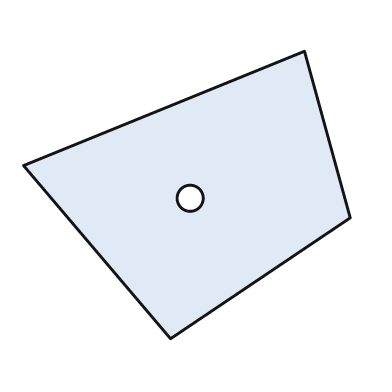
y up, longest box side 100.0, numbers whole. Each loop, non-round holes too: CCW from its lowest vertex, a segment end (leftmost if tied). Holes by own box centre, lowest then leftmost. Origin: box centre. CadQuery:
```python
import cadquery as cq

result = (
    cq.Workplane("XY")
    .moveTo(-5.0, -44.0)
    .lineTo(50.0, -7.0)
    .lineTo(36.0, 44.0)
    .lineTo(-50.0, 9.0)
    .close()
    .moveTo(1.0, -1.0)
    .circle(4.0)
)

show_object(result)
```